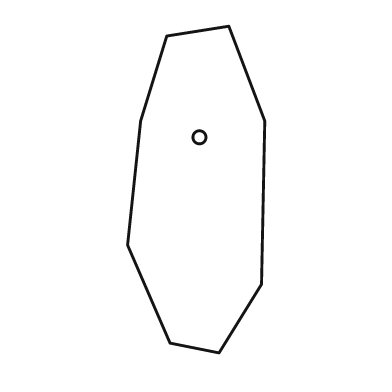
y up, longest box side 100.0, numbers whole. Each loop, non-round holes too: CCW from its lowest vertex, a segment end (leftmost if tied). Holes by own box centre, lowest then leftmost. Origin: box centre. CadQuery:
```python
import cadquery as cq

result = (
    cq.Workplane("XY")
    .moveTo(7.0, -50.0)
    .lineTo(20.0, -29.0)
    .lineTo(21.0, 21.0)
    .lineTo(10.0, 50.0)
    .lineTo(-9.0, 47.0)
    .lineTo(-17.0, 21.0)
    .lineTo(-21.0, -17.0)
    .lineTo(-8.0, -47.0)
    .close()
    .moveTo(1.0, 16.0)
    .circle(2.0)
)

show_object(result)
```